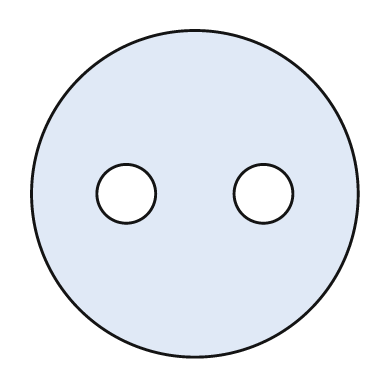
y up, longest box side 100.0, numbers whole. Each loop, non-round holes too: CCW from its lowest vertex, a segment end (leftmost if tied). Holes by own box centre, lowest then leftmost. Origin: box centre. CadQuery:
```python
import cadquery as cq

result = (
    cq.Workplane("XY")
    .moveTo(0.0, 0.0)
    .circle(50.0)
    .moveTo(-21.0, 0.0)
    .circle(9.0)
    .moveTo(21.0, 0.0)
    .circle(9.0)
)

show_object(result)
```